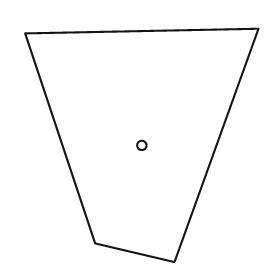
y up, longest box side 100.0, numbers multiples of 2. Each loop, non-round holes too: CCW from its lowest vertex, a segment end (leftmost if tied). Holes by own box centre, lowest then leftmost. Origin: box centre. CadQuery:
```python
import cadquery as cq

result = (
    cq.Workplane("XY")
    .moveTo(14.0, -50.0)
    .lineTo(50.0, 50.0)
    .lineTo(-50.0, 48.0)
    .lineTo(-20.0, -42.0)
    .close()
    .moveTo(0.0, 0.0)
    .circle(2.0)
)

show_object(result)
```